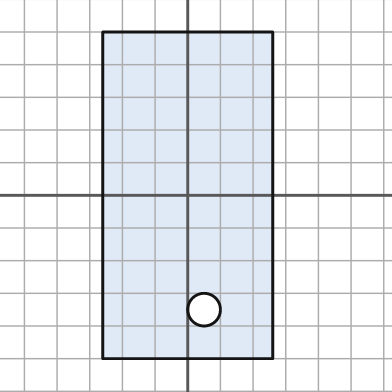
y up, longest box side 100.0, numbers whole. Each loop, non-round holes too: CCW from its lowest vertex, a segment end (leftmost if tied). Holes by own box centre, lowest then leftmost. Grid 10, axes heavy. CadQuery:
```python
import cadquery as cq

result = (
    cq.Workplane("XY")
    .moveTo(-26.0, -50.0)
    .lineTo(26.0, -50.0)
    .lineTo(26.0, 50.0)
    .lineTo(-26.0, 50.0)
    .close()
    .moveTo(5.0, -35.0)
    .circle(5.0)
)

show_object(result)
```